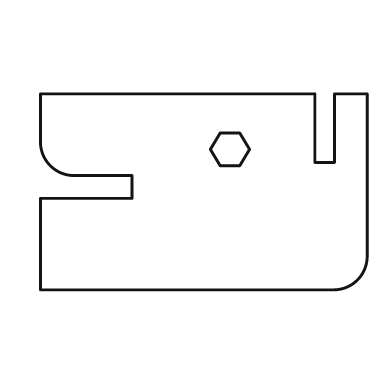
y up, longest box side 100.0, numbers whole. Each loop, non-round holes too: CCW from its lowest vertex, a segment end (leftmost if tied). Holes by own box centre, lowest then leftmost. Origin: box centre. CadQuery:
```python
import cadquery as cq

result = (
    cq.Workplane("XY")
    .moveTo(-50.0, -30.0)
    .lineTo(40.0, -30.0)
    .threePointArc((47.0, -27.0), (50.0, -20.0))
    .lineTo(50.0, 30.0)
    .lineTo(40.0, 30.0)
    .lineTo(40.0, 9.0)
    .lineTo(34.0, 9.0)
    .lineTo(34.0, 30.0)
    .lineTo(-50.0, 30.0)
    .lineTo(-50.0, 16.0)
    .threePointArc((-47.0, 8.0), (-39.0, 5.0))
    .lineTo(-22.0, 5.0)
    .lineTo(-22.0, -2.0)
    .lineTo(-50.0, -2.0)
    .close()
    .moveTo(5.0, 8.0)
    .lineTo(11.0, 8.0)
    .lineTo(14.0, 13.0)
    .lineTo(11.0, 18.0)
    .lineTo(5.0, 18.0)
    .lineTo(2.0, 13.0)
    .close()
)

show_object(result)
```